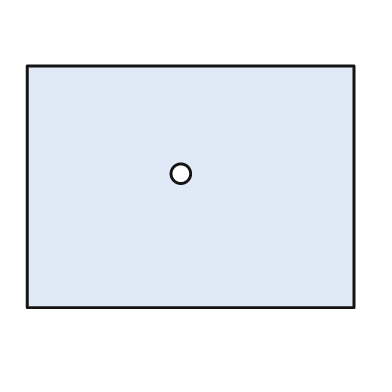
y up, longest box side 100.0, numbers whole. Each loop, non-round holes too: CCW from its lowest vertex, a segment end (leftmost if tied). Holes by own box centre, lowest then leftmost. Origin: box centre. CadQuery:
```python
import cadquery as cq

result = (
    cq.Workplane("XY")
    .moveTo(-50.0, -37.0)
    .lineTo(50.0, -37.0)
    .lineTo(50.0, 37.0)
    .lineTo(-50.0, 37.0)
    .close()
    .moveTo(-3.0, 4.0)
    .circle(3.0)
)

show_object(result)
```